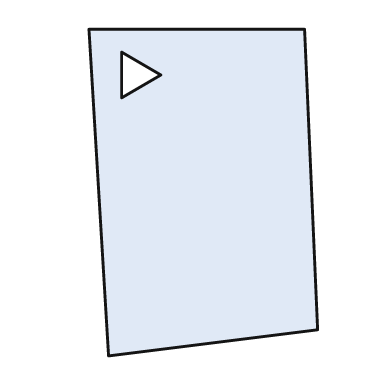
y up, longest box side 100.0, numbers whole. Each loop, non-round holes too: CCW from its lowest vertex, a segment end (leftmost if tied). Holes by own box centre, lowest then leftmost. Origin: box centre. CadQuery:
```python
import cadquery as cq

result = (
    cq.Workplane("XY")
    .moveTo(-29.0, -50.0)
    .lineTo(35.0, -42.0)
    .lineTo(31.0, 50.0)
    .lineTo(-35.0, 50.0)
    .close()
    .moveTo(-25.0, 29.0)
    .lineTo(-13.0, 36.0)
    .lineTo(-25.0, 43.0)
    .close()
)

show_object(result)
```